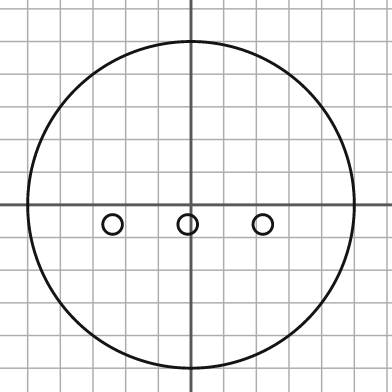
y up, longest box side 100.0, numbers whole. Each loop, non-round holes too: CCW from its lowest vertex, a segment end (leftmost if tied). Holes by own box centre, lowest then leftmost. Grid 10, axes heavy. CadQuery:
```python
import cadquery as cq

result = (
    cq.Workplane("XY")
    .moveTo(0.0, 0.0)
    .circle(50.0)
    .moveTo(-24.0, -6.0)
    .circle(3.0)
    .moveTo(-1.0, -6.0)
    .circle(3.0)
    .moveTo(22.0, -6.0)
    .circle(3.0)
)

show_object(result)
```